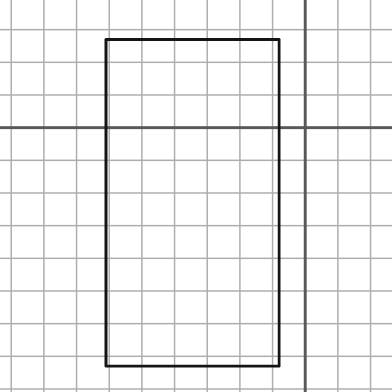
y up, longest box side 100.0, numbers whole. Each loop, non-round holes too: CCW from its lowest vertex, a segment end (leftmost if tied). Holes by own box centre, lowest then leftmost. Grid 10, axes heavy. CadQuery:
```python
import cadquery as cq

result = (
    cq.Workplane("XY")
    .moveTo(-61.0, -73.0)
    .lineTo(-8.0, -73.0)
    .lineTo(-8.0, 27.0)
    .lineTo(-61.0, 27.0)
    .close()
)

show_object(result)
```